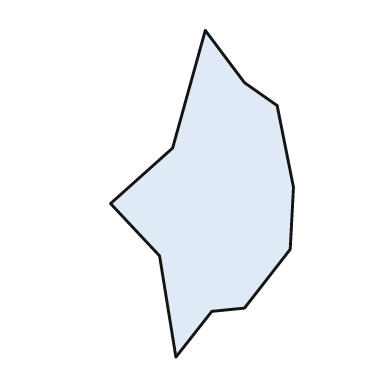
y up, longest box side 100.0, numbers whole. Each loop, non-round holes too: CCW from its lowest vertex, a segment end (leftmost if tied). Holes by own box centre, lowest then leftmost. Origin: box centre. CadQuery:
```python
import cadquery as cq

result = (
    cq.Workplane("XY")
    .moveTo(-8.0, -50.0)
    .lineTo(3.0, -36.0)
    .lineTo(13.0, -35.0)
    .lineTo(27.0, -17.0)
    .lineTo(28.0, 2.0)
    .lineTo(23.0, 27.0)
    .lineTo(13.0, 34.0)
    .lineTo(1.0, 50.0)
    .lineTo(-9.0, 14.0)
    .lineTo(-28.0, -3.0)
    .lineTo(-13.0, -19.0)
    .close()
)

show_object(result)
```